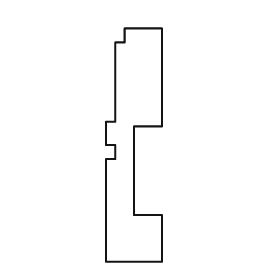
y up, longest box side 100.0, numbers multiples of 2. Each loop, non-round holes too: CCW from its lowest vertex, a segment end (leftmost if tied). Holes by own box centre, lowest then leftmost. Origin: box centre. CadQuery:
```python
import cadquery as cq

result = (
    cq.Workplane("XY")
    .moveTo(-12.0, -50.0)
    .lineTo(12.0, -50.0)
    .lineTo(12.0, -30.0)
    .lineTo(0.0, -30.0)
    .lineTo(0.0, 8.0)
    .lineTo(12.0, 8.0)
    .lineTo(12.0, 50.0)
    .lineTo(-4.0, 50.0)
    .lineTo(-4.0, 44.0)
    .lineTo(-8.0, 44.0)
    .lineTo(-8.0, 10.0)
    .lineTo(-12.0, 10.0)
    .lineTo(-12.0, 0.0)
    .lineTo(-8.0, 0.0)
    .lineTo(-8.0, -6.0)
    .lineTo(-12.0, -6.0)
    .close()
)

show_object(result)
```